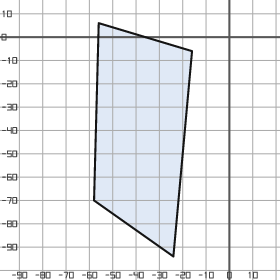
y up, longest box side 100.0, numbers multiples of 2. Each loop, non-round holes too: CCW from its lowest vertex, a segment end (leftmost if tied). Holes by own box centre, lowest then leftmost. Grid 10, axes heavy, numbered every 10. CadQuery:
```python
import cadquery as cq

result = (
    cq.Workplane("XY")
    .moveTo(-24.0, -94.0)
    .lineTo(-16.0, -6.0)
    .lineTo(-56.0, 6.0)
    .lineTo(-58.0, -70.0)
    .close()
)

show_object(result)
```